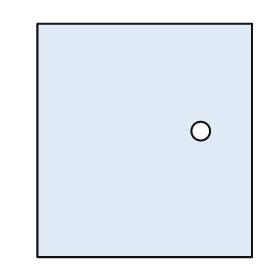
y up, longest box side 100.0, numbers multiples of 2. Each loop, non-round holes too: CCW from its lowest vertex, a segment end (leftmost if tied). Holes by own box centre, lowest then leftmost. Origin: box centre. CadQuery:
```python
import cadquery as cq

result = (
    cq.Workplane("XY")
    .moveTo(-46.0, -50.0)
    .lineTo(46.0, -50.0)
    .lineTo(46.0, 50.0)
    .lineTo(-46.0, 50.0)
    .close()
    .moveTo(24.0, 4.0)
    .circle(4.0)
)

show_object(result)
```